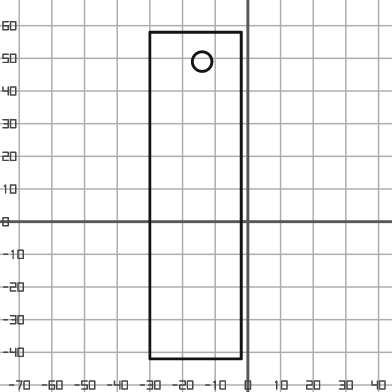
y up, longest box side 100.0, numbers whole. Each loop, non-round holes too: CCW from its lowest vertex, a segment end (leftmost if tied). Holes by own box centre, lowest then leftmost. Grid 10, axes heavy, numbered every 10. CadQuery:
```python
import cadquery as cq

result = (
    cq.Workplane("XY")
    .moveTo(-30.0, -42.0)
    .lineTo(-2.0, -42.0)
    .lineTo(-2.0, 58.0)
    .lineTo(-30.0, 58.0)
    .close()
    .moveTo(-14.0, 49.0)
    .circle(3.0)
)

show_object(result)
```